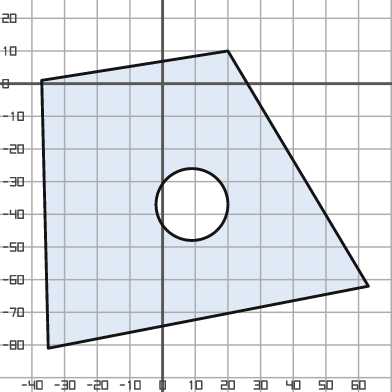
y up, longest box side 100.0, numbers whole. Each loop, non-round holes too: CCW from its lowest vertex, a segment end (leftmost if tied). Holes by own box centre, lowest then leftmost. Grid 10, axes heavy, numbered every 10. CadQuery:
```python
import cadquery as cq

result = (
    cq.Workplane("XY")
    .moveTo(-35.0, -81.0)
    .lineTo(63.0, -62.0)
    .lineTo(20.0, 10.0)
    .lineTo(-37.0, 1.0)
    .close()
    .moveTo(9.0, -37.0)
    .circle(11.0)
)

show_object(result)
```